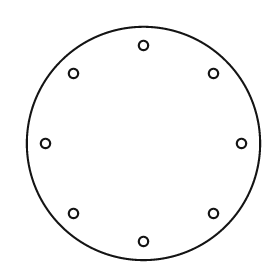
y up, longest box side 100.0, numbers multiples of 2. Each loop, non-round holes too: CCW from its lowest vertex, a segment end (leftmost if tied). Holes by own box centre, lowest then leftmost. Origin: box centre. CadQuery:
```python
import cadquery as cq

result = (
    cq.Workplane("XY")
    .moveTo(0.0, 0.0)
    .circle(50.0)
    .moveTo(0.0, -42.0)
    .circle(2.0)
    .moveTo(-30.0, -30.0)
    .circle(2.0)
    .moveTo(30.0, -30.0)
    .circle(2.0)
    .moveTo(-42.0, 0.0)
    .circle(2.0)
    .moveTo(42.0, 0.0)
    .circle(2.0)
    .moveTo(-30.0, 30.0)
    .circle(2.0)
    .moveTo(30.0, 30.0)
    .circle(2.0)
    .moveTo(0.0, 42.0)
    .circle(2.0)
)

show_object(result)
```